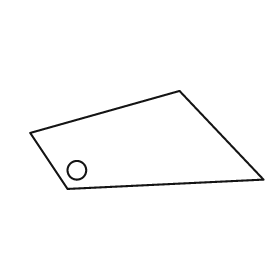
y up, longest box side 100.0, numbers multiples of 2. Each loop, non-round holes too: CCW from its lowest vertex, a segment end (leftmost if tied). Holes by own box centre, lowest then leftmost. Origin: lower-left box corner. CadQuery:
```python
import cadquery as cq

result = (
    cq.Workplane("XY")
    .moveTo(16.0, 0.0)
    .lineTo(100.0, 4.0)
    .lineTo(64.0, 42.0)
    .lineTo(0.0, 24.0)
    .close()
    .moveTo(20.0, 8.0)
    .circle(4.0)
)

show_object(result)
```